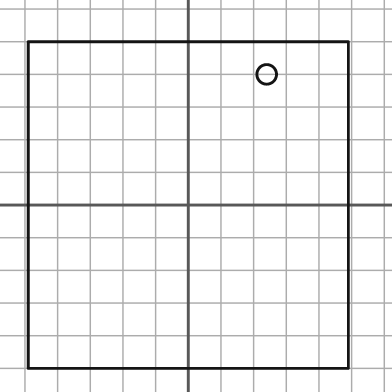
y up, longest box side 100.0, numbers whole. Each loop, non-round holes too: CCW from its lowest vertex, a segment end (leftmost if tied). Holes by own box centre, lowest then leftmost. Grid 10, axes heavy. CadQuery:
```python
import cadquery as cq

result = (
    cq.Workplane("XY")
    .moveTo(-49.0, -50.0)
    .lineTo(49.0, -50.0)
    .lineTo(49.0, 50.0)
    .lineTo(-49.0, 50.0)
    .close()
    .moveTo(24.0, 40.0)
    .circle(3.0)
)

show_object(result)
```